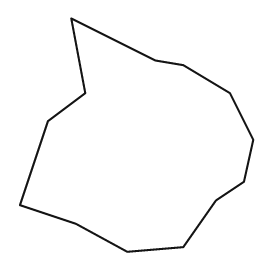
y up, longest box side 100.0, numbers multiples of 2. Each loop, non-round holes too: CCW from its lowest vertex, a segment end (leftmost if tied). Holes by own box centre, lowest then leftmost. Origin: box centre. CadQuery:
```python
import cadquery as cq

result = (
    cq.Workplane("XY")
    .moveTo(-4.0, -50.0)
    .lineTo(20.0, -48.0)
    .lineTo(34.0, -28.0)
    .lineTo(46.0, -20.0)
    .lineTo(50.0, -2.0)
    .lineTo(40.0, 18.0)
    .lineTo(20.0, 30.0)
    .lineTo(8.0, 32.0)
    .lineTo(-28.0, 50.0)
    .lineTo(-22.0, 18.0)
    .lineTo(-38.0, 6.0)
    .lineTo(-50.0, -30.0)
    .lineTo(-26.0, -38.0)
    .close()
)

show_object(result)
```